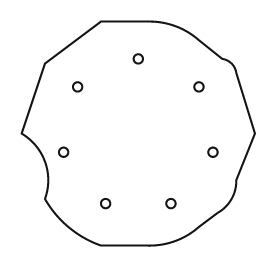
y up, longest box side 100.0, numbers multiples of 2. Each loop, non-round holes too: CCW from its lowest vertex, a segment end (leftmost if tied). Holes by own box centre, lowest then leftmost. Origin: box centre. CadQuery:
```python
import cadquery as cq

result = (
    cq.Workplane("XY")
    .moveTo(-16.0, -48.0)
    .lineTo(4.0, -48.0)
    .threePointArc((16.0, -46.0), (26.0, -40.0))
    .lineTo(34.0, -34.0)
    .threePointArc((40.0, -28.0), (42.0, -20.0))
    .lineTo(50.0, 0.0)
    .lineTo(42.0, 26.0)
    .threePointArc((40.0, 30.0), (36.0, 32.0))
    .lineTo(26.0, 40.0)
    .threePointArc((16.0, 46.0), (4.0, 48.0))
    .lineTo(-16.0, 48.0)
    .lineTo(-40.0, 30.0)
    .lineTo(-50.0, 0.0)
    .threePointArc((-40.0, -12.0), (-40.0, -28.0))
    .threePointArc((-30.0, -40.0), (-16.0, -48.0))
    .close()
    .moveTo(-14.0, -30.0)
    .circle(2.0)
    .moveTo(14.0, -30.0)
    .circle(2.0)
    .moveTo(-32.0, -8.0)
    .circle(2.0)
    .moveTo(32.0, -8.0)
    .circle(2.0)
    .moveTo(-26.0, 20.0)
    .circle(2.0)
    .moveTo(26.0, 20.0)
    .circle(2.0)
    .moveTo(0.0, 32.0)
    .circle(2.0)
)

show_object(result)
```